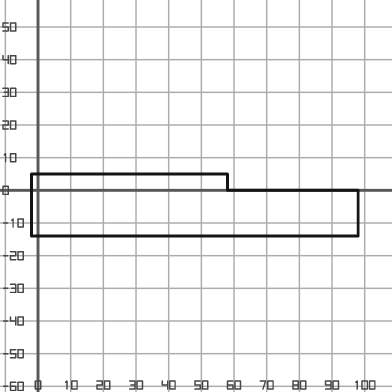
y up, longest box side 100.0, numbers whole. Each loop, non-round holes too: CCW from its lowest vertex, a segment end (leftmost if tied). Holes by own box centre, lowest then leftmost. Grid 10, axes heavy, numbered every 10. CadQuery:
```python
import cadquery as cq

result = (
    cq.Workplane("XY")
    .moveTo(-2.0, -14.0)
    .lineTo(98.0, -14.0)
    .lineTo(98.0, 0.0)
    .lineTo(58.0, 0.0)
    .lineTo(58.0, 5.0)
    .lineTo(-2.0, 5.0)
    .close()
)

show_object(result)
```